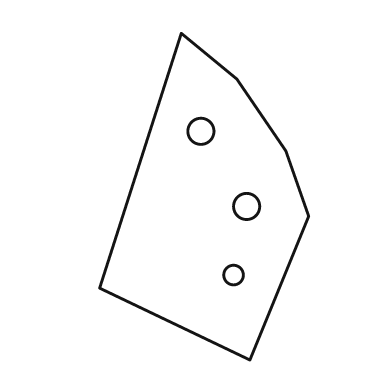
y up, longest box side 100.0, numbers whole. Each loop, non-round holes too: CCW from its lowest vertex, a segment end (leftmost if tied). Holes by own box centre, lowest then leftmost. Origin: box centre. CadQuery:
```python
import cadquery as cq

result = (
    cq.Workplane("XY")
    .moveTo(14.0, -50.0)
    .lineTo(32.0, -6.0)
    .lineTo(25.0, 14.0)
    .lineTo(10.0, 36.0)
    .lineTo(-7.0, 50.0)
    .lineTo(-32.0, -28.0)
    .close()
    .moveTo(9.0, -24.0)
    .circle(3.0)
    .moveTo(13.0, -3.0)
    .circle(4.0)
    .moveTo(-1.0, 20.0)
    .circle(4.0)
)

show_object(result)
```